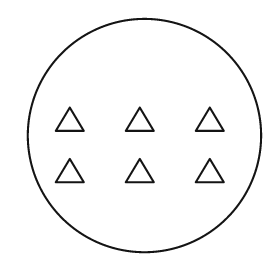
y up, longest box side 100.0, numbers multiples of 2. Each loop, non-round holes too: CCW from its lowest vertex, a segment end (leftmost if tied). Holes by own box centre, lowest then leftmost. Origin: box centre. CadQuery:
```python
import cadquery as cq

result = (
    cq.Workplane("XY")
    .moveTo(0.0, 0.0)
    .circle(50.0)
    .moveTo(-38.0, -20.0)
    .lineTo(-26.0, -20.0)
    .lineTo(-32.0, -10.0)
    .close()
    .moveTo(-8.0, -20.0)
    .lineTo(4.0, -20.0)
    .lineTo(-2.0, -10.0)
    .close()
    .moveTo(22.0, -20.0)
    .lineTo(34.0, -20.0)
    .lineTo(28.0, -10.0)
    .close()
    .moveTo(-38.0, 2.0)
    .lineTo(-26.0, 2.0)
    .lineTo(-32.0, 12.0)
    .close()
    .moveTo(-8.0, 2.0)
    .lineTo(4.0, 2.0)
    .lineTo(-2.0, 12.0)
    .close()
    .moveTo(22.0, 2.0)
    .lineTo(34.0, 2.0)
    .lineTo(28.0, 12.0)
    .close()
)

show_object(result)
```